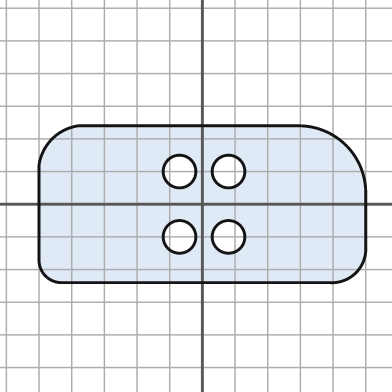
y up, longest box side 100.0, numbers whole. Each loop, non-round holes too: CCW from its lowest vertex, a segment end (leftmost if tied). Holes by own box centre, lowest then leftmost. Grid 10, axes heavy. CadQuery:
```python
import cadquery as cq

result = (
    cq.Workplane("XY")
    .moveTo(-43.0, -24.0)
    .lineTo(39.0, -24.0)
    .threePointArc((47.0, -21.0), (50.0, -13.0))
    .lineTo(50.0, 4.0)
    .threePointArc((44.0, 18.0), (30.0, 24.0))
    .lineTo(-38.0, 24.0)
    .threePointArc((-46.0, 20.0), (-50.0, 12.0))
    .lineTo(-50.0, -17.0)
    .threePointArc((-48.0, -22.0), (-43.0, -24.0))
    .close()
    .moveTo(-7.0, -10.0)
    .circle(5.0)
    .moveTo(8.0, -10.0)
    .circle(5.0)
    .moveTo(-7.0, 10.0)
    .circle(5.0)
    .moveTo(8.0, 10.0)
    .circle(5.0)
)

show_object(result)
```